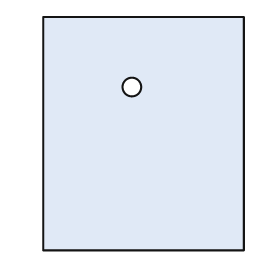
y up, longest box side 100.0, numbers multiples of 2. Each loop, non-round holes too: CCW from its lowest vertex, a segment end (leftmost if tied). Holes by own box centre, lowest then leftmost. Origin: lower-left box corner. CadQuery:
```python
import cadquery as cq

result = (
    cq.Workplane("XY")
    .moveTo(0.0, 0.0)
    .lineTo(86.0, 0.0)
    .lineTo(86.0, 100.0)
    .lineTo(0.0, 100.0)
    .close()
    .moveTo(38.0, 70.0)
    .circle(4.0)
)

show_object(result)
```